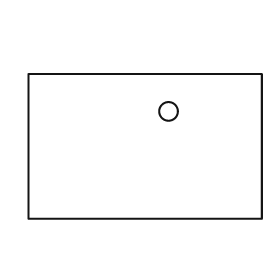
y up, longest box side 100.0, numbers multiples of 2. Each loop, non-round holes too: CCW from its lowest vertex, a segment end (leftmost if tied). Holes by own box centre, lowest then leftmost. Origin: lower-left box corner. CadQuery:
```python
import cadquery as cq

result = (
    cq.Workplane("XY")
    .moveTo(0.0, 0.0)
    .lineTo(100.0, 0.0)
    .lineTo(100.0, 62.0)
    .lineTo(0.0, 62.0)
    .close()
    .moveTo(60.0, 46.0)
    .circle(4.0)
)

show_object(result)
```